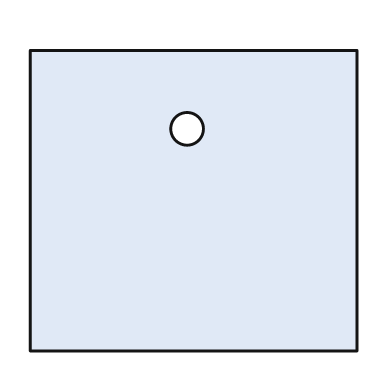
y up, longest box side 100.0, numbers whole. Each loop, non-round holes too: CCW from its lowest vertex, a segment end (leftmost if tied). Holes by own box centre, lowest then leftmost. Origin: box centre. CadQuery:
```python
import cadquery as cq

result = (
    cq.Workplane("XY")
    .moveTo(-50.0, -46.0)
    .lineTo(50.0, -46.0)
    .lineTo(50.0, 46.0)
    .lineTo(-50.0, 46.0)
    .close()
    .moveTo(-2.0, 22.0)
    .circle(5.0)
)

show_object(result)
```